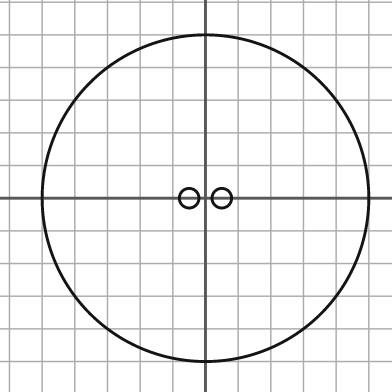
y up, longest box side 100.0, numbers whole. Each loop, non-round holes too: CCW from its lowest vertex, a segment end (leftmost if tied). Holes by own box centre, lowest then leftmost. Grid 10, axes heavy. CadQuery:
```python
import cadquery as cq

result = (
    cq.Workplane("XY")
    .moveTo(0.0, 0.0)
    .circle(50.0)
    .moveTo(-5.0, 0.0)
    .circle(3.0)
    .moveTo(5.0, 0.0)
    .circle(3.0)
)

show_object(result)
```